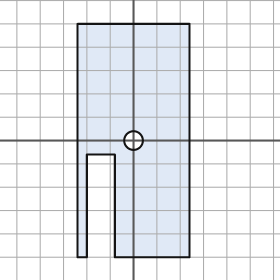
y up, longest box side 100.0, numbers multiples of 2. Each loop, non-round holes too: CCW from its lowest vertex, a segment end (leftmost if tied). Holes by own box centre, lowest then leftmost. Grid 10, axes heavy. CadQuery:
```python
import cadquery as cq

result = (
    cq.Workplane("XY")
    .moveTo(-24.0, -50.0)
    .lineTo(-20.0, -50.0)
    .lineTo(-20.0, -6.0)
    .lineTo(-8.0, -6.0)
    .lineTo(-8.0, -50.0)
    .lineTo(24.0, -50.0)
    .lineTo(24.0, 50.0)
    .lineTo(-24.0, 50.0)
    .close()
    .moveTo(0.0, 0.0)
    .circle(4.0)
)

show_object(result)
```